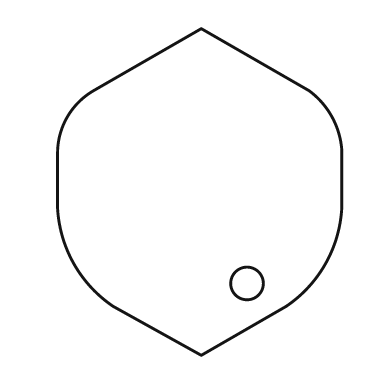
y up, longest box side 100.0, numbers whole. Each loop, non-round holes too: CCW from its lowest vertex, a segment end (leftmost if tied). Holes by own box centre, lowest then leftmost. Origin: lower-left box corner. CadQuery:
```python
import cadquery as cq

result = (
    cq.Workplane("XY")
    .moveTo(44.0, 0.0)
    .lineTo(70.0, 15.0)
    .threePointArc((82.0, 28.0), (87.0, 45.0))
    .lineTo(87.0, 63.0)
    .threePointArc((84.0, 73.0), (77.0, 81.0))
    .lineTo(44.0, 100.0)
    .lineTo(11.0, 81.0)
    .threePointArc((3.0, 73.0), (0.0, 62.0))
    .lineTo(0.0, 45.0)
    .threePointArc((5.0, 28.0), (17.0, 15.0))
    .close()
    .moveTo(58.0, 22.0)
    .circle(5.0)
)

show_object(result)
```